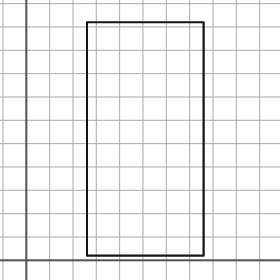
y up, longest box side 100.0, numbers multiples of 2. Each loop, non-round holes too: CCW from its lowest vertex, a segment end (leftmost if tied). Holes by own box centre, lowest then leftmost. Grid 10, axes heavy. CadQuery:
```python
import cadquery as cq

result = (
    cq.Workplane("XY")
    .moveTo(26.0, 2.0)
    .lineTo(76.0, 2.0)
    .lineTo(76.0, 102.0)
    .lineTo(26.0, 102.0)
    .close()
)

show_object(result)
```